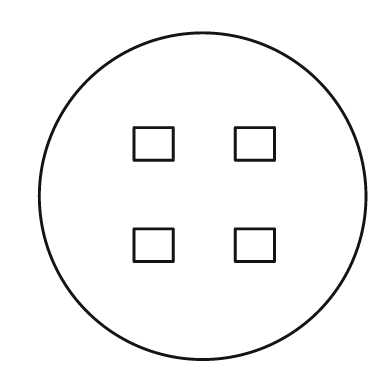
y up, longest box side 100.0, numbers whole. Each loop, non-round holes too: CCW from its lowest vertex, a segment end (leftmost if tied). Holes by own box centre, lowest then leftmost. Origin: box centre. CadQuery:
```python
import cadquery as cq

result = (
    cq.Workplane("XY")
    .moveTo(0.0, 0.0)
    .circle(50.0)
    .moveTo(-21.0, -20.0)
    .lineTo(-9.0, -20.0)
    .lineTo(-9.0, -10.0)
    .lineTo(-21.0, -10.0)
    .close()
    .moveTo(10.0, -20.0)
    .lineTo(22.0, -20.0)
    .lineTo(22.0, -10.0)
    .lineTo(10.0, -10.0)
    .close()
    .moveTo(-21.0, 11.0)
    .lineTo(-9.0, 11.0)
    .lineTo(-9.0, 21.0)
    .lineTo(-21.0, 21.0)
    .close()
    .moveTo(10.0, 11.0)
    .lineTo(22.0, 11.0)
    .lineTo(22.0, 21.0)
    .lineTo(10.0, 21.0)
    .close()
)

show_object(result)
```